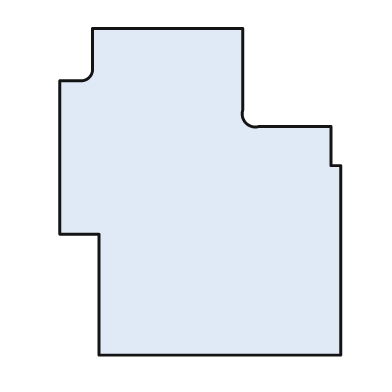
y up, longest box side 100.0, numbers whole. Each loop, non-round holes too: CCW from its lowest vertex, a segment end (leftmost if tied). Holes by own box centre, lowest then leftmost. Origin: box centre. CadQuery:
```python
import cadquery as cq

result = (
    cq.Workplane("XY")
    .moveTo(-31.0, -50.0)
    .lineTo(43.0, -50.0)
    .lineTo(43.0, 8.0)
    .lineTo(40.0, 8.0)
    .lineTo(40.0, 20.0)
    .lineTo(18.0, 20.0)
    .threePointArc((14.0, 21.0), (13.0, 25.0))
    .lineTo(13.0, 50.0)
    .lineTo(-33.0, 50.0)
    .lineTo(-33.0, 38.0)
    .threePointArc((-34.0, 35.0), (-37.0, 34.0))
    .lineTo(-43.0, 34.0)
    .lineTo(-43.0, -13.0)
    .lineTo(-31.0, -13.0)
    .close()
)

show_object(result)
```